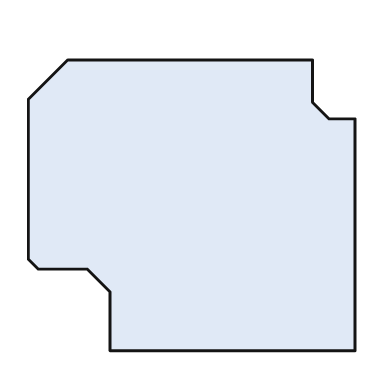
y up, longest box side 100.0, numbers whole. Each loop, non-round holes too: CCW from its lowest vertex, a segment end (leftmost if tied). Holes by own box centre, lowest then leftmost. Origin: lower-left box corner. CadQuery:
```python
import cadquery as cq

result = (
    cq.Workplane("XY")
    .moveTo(25.0, 0.0)
    .lineTo(100.0, 0.0)
    .lineTo(100.0, 71.0)
    .lineTo(92.0, 71.0)
    .lineTo(87.0, 76.0)
    .lineTo(87.0, 89.0)
    .lineTo(12.0, 89.0)
    .lineTo(0.0, 77.0)
    .lineTo(0.0, 28.0)
    .lineTo(3.0, 25.0)
    .lineTo(18.0, 25.0)
    .lineTo(25.0, 18.0)
    .close()
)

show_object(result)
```